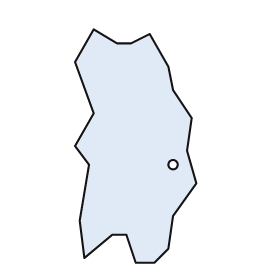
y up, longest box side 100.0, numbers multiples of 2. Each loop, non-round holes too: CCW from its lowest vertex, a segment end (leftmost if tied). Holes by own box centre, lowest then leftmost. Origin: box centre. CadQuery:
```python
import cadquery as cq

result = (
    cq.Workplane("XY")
    .moveTo(0.0, -50.0)
    .lineTo(8.0, -50.0)
    .lineTo(14.0, -44.0)
    .lineTo(16.0, -30.0)
    .lineTo(26.0, -16.0)
    .lineTo(22.0, -2.0)
    .lineTo(24.0, 12.0)
    .lineTo(16.0, 24.0)
    .lineTo(14.0, 34.0)
    .lineTo(6.0, 48.0)
    .lineTo(-2.0, 44.0)
    .lineTo(-8.0, 44.0)
    .lineTo(-18.0, 50.0)
    .lineTo(-26.0, 36.0)
    .lineTo(-18.0, 14.0)
    .lineTo(-26.0, 0.0)
    .lineTo(-20.0, -8.0)
    .lineTo(-24.0, -32.0)
    .lineTo(-22.0, -48.0)
    .lineTo(-10.0, -38.0)
    .lineTo(-4.0, -38.0)
    .close()
    .moveTo(16.0, -8.0)
    .circle(2.0)
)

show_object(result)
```